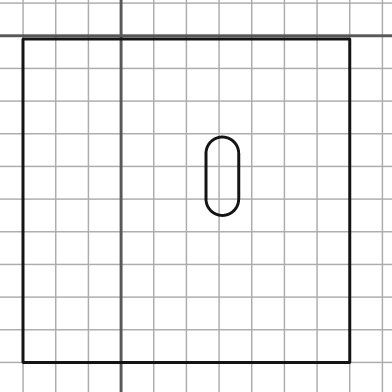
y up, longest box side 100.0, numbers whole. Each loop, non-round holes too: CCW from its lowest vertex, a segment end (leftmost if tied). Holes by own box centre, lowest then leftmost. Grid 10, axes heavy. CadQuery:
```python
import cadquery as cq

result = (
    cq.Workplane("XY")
    .moveTo(-30.0, -100.0)
    .lineTo(70.0, -100.0)
    .lineTo(70.0, -1.0)
    .lineTo(-30.0, -1.0)
    .close()
    .moveTo(26.0, -50.0)
    .threePointArc((31.0, -55.0), (36.0, -50.0))
    .lineTo(36.0, -36.0)
    .threePointArc((31.0, -31.0), (26.0, -36.0))
    .close()
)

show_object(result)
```